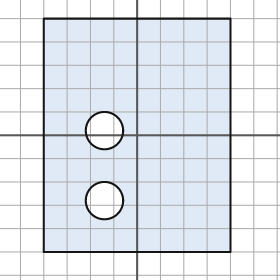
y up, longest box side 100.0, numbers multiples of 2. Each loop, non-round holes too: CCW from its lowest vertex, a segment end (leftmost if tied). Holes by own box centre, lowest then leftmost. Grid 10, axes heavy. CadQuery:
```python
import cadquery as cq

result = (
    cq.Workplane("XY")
    .moveTo(-40.0, -50.0)
    .lineTo(40.0, -50.0)
    .lineTo(40.0, 50.0)
    .lineTo(-40.0, 50.0)
    .close()
    .moveTo(-14.0, -28.0)
    .circle(8.0)
    .moveTo(-14.0, 2.0)
    .circle(8.0)
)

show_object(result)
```